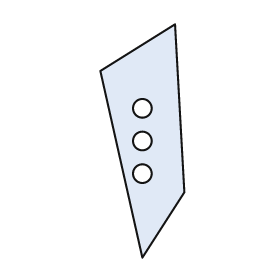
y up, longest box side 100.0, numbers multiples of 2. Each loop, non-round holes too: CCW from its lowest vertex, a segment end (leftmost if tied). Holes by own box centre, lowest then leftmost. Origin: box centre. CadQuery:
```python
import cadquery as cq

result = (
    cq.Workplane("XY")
    .moveTo(0.0, -50.0)
    .lineTo(18.0, -22.0)
    .lineTo(14.0, 50.0)
    .lineTo(-18.0, 30.0)
    .close()
    .moveTo(0.0, -14.0)
    .circle(4.0)
    .moveTo(0.0, 0.0)
    .circle(4.0)
    .moveTo(0.0, 14.0)
    .circle(4.0)
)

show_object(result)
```